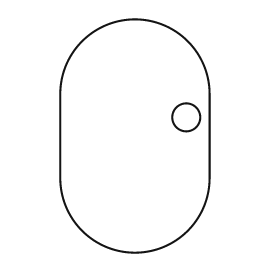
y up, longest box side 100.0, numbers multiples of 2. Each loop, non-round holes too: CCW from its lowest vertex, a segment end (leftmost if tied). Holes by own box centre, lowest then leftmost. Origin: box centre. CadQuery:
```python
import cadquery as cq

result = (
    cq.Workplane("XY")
    .moveTo(-32.0, -18.0)
    .threePointArc((0.0, -50.0), (32.0, -18.0))
    .lineTo(32.0, 18.0)
    .threePointArc((0.0, 50.0), (-32.0, 18.0))
    .close()
    .moveTo(22.0, 8.0)
    .circle(6.0)
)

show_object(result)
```